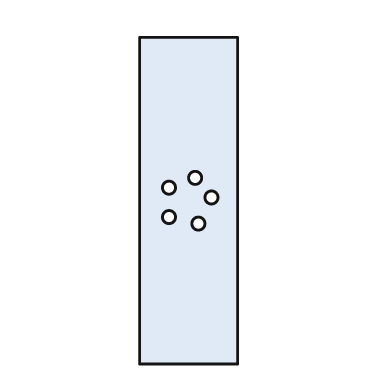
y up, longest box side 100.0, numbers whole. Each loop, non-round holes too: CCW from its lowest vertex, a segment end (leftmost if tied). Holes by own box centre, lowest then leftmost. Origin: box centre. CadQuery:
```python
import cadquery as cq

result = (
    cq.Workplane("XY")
    .moveTo(-15.0, -50.0)
    .lineTo(15.0, -50.0)
    .lineTo(15.0, 50.0)
    .lineTo(-15.0, 50.0)
    .close()
    .moveTo(3.0, -7.0)
    .circle(2.0)
    .moveTo(-6.0, -5.0)
    .circle(2.0)
    .moveTo(7.0, 1.0)
    .circle(2.0)
    .moveTo(-6.0, 4.0)
    .circle(2.0)
    .moveTo(2.0, 7.0)
    .circle(2.0)
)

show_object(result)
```